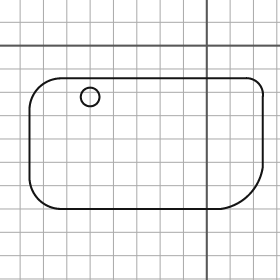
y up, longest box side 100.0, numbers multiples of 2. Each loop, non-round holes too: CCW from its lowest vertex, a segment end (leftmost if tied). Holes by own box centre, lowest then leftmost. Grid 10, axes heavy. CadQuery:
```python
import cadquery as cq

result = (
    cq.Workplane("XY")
    .moveTo(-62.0, -70.0)
    .lineTo(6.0, -70.0)
    .threePointArc((18.0, -64.0), (24.0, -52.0))
    .lineTo(24.0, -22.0)
    .threePointArc((22.0, -16.0), (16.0, -14.0))
    .lineTo(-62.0, -14.0)
    .threePointArc((-72.0, -18.0), (-76.0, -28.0))
    .lineTo(-76.0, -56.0)
    .threePointArc((-72.0, -66.0), (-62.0, -70.0))
    .close()
    .moveTo(-50.0, -22.0)
    .circle(4.0)
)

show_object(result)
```